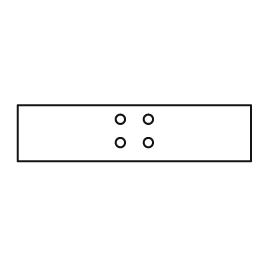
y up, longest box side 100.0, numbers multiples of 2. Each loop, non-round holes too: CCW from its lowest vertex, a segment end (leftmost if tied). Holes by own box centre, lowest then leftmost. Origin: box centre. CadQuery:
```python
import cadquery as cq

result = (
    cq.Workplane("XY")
    .moveTo(-50.0, -12.0)
    .lineTo(50.0, -12.0)
    .lineTo(50.0, 12.0)
    .lineTo(-50.0, 12.0)
    .close()
    .moveTo(-6.0, -4.0)
    .circle(2.0)
    .moveTo(6.0, -4.0)
    .circle(2.0)
    .moveTo(-6.0, 6.0)
    .circle(2.0)
    .moveTo(6.0, 6.0)
    .circle(2.0)
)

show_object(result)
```